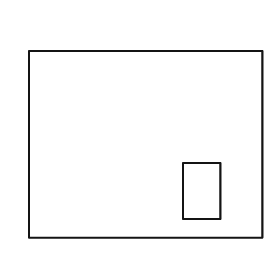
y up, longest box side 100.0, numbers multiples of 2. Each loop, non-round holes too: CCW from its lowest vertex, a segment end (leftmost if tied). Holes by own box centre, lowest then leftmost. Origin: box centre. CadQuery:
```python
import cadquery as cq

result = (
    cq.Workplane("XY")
    .moveTo(-50.0, -40.0)
    .lineTo(50.0, -40.0)
    .lineTo(50.0, 40.0)
    .lineTo(-50.0, 40.0)
    .close()
    .moveTo(16.0, -32.0)
    .lineTo(32.0, -32.0)
    .lineTo(32.0, -8.0)
    .lineTo(16.0, -8.0)
    .close()
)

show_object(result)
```